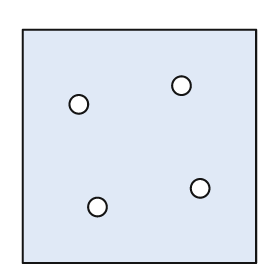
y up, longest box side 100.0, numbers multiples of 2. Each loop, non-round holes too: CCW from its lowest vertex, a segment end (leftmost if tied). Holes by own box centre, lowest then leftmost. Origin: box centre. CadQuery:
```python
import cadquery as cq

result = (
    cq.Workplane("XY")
    .moveTo(-50.0, -50.0)
    .lineTo(50.0, -50.0)
    .lineTo(50.0, 50.0)
    .lineTo(-50.0, 50.0)
    .close()
    .moveTo(-18.0, -26.0)
    .circle(4.0)
    .moveTo(26.0, -18.0)
    .circle(4.0)
    .moveTo(-26.0, 18.0)
    .circle(4.0)
    .moveTo(18.0, 26.0)
    .circle(4.0)
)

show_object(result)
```